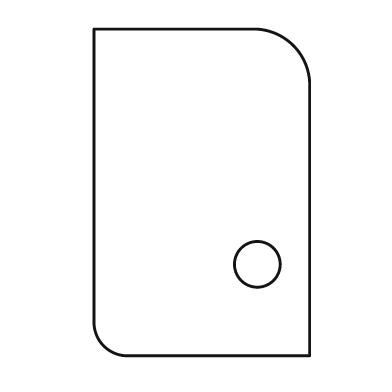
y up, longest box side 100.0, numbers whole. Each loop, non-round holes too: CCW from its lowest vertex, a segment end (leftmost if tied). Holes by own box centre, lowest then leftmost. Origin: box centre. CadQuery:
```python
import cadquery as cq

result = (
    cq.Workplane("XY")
    .moveTo(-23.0, -50.0)
    .lineTo(33.0, -50.0)
    .lineTo(33.0, 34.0)
    .threePointArc((28.0, 45.0), (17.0, 50.0))
    .lineTo(-33.0, 50.0)
    .lineTo(-33.0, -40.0)
    .threePointArc((-30.0, -47.0), (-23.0, -50.0))
    .close()
    .moveTo(17.0, -22.0)
    .circle(7.0)
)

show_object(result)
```